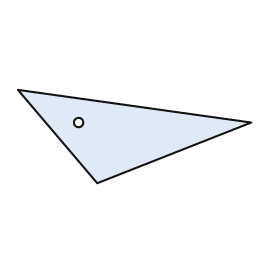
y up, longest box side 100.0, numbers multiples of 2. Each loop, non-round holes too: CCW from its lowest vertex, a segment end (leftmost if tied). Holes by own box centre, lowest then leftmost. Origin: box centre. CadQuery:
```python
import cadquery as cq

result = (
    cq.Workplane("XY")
    .moveTo(-16.0, -20.0)
    .lineTo(50.0, 6.0)
    .lineTo(-50.0, 20.0)
    .close()
    .moveTo(-24.0, 6.0)
    .circle(2.0)
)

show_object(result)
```